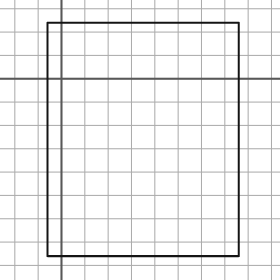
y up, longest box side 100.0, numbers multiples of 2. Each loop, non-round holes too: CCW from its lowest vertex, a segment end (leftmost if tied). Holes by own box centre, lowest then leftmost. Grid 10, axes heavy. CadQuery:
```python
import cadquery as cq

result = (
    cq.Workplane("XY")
    .moveTo(-6.0, -76.0)
    .lineTo(76.0, -76.0)
    .lineTo(76.0, 24.0)
    .lineTo(-6.0, 24.0)
    .close()
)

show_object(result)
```